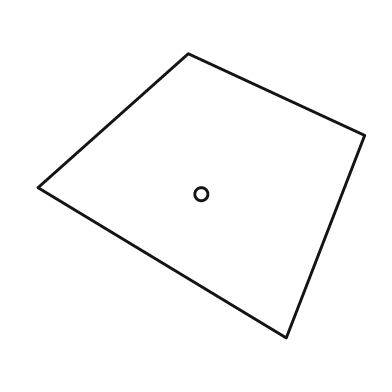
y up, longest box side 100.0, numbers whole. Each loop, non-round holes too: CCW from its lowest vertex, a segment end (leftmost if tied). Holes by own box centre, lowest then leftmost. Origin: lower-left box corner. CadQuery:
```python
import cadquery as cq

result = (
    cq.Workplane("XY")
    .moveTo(76.0, 0.0)
    .lineTo(100.0, 62.0)
    .lineTo(46.0, 87.0)
    .lineTo(0.0, 46.0)
    .close()
    .moveTo(50.0, 44.0)
    .circle(2.0)
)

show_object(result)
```